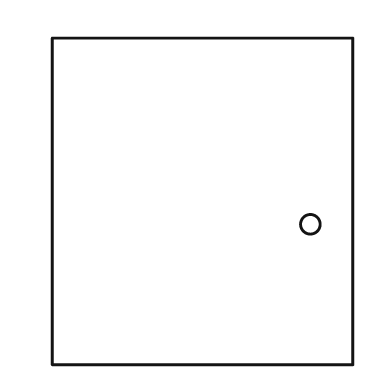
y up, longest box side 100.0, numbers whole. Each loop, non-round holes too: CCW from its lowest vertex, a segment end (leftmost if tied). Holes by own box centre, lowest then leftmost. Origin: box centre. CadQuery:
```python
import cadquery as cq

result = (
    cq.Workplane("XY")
    .moveTo(-46.0, -50.0)
    .lineTo(46.0, -50.0)
    .lineTo(46.0, 50.0)
    .lineTo(-46.0, 50.0)
    .close()
    .moveTo(33.0, -7.0)
    .circle(3.0)
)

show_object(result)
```